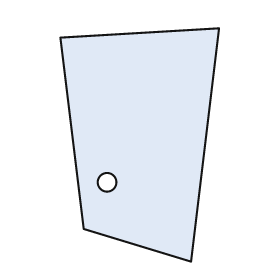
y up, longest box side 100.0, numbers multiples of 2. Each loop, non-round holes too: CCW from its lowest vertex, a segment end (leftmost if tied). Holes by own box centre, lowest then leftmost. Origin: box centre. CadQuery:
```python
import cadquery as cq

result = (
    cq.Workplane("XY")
    .moveTo(22.0, -50.0)
    .lineTo(34.0, 50.0)
    .lineTo(-34.0, 46.0)
    .lineTo(-24.0, -36.0)
    .close()
    .moveTo(-14.0, -16.0)
    .circle(4.0)
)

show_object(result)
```